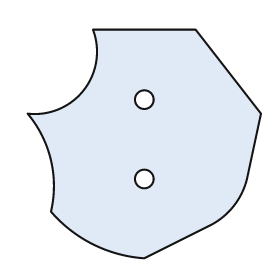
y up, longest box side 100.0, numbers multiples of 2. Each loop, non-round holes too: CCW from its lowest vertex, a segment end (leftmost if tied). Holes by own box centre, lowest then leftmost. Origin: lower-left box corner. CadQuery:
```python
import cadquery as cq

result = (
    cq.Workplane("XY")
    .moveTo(50.0, 0.0)
    .lineTo(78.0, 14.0)
    .threePointArc((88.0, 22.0), (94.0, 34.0))
    .lineTo(100.0, 62.0)
    .lineTo(72.0, 98.0)
    .lineTo(28.0, 98.0)
    .threePointArc((24.0, 72.0), (0.0, 62.0))
    .threePointArc((10.0, 42.0), (10.0, 20.0))
    .threePointArc((28.0, 6.0), (50.0, 0.0))
    .close()
    .moveTo(50.0, 34.0)
    .circle(4.0)
    .moveTo(50.0, 68.0)
    .circle(4.0)
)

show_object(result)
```